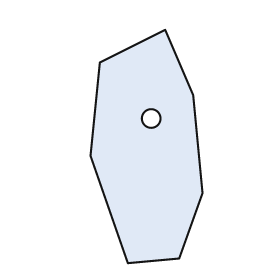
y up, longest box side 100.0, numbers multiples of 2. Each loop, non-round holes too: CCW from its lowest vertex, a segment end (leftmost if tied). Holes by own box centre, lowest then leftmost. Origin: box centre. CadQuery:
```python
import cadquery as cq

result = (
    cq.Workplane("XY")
    .moveTo(-8.0, -50.0)
    .lineTo(14.0, -48.0)
    .lineTo(24.0, -20.0)
    .lineTo(20.0, 22.0)
    .lineTo(8.0, 50.0)
    .lineTo(-20.0, 36.0)
    .lineTo(-24.0, -4.0)
    .close()
    .moveTo(2.0, 12.0)
    .circle(4.0)
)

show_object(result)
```